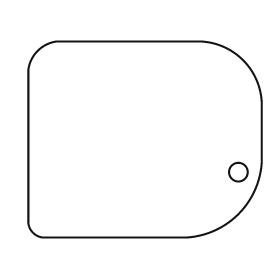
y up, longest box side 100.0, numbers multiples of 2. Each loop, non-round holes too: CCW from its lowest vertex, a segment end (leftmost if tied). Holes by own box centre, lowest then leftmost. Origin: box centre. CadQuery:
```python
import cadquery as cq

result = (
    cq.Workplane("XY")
    .moveTo(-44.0, -42.0)
    .lineTo(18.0, -42.0)
    .threePointArc((40.0, -32.0), (50.0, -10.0))
    .lineTo(50.0, 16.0)
    .threePointArc((42.0, 34.0), (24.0, 42.0))
    .lineTo(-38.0, 42.0)
    .threePointArc((-46.0, 38.0), (-50.0, 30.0))
    .lineTo(-50.0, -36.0)
    .threePointArc((-48.0, -40.0), (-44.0, -42.0))
    .close()
    .moveTo(40.0, -14.0)
    .circle(4.0)
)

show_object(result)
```